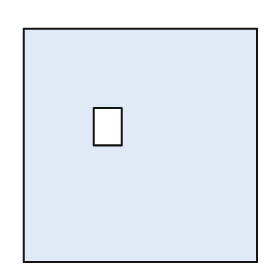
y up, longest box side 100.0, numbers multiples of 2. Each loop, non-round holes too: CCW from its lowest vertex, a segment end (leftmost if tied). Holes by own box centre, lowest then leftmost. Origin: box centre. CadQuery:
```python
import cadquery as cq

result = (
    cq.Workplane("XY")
    .moveTo(-50.0, -50.0)
    .lineTo(50.0, -50.0)
    .lineTo(50.0, 50.0)
    .lineTo(-50.0, 50.0)
    .close()
    .moveTo(-20.0, 0.0)
    .lineTo(-8.0, 0.0)
    .lineTo(-8.0, 16.0)
    .lineTo(-20.0, 16.0)
    .close()
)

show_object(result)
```